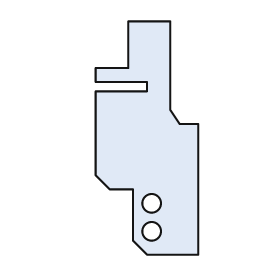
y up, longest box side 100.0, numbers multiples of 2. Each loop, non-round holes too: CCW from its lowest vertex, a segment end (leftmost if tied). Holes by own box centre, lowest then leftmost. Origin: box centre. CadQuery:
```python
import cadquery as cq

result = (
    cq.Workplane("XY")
    .moveTo(0.0, -50.0)
    .lineTo(22.0, -50.0)
    .lineTo(22.0, 6.0)
    .lineTo(14.0, 6.0)
    .lineTo(10.0, 12.0)
    .lineTo(10.0, 50.0)
    .lineTo(-8.0, 50.0)
    .lineTo(-8.0, 30.0)
    .lineTo(-22.0, 30.0)
    .lineTo(-22.0, 24.0)
    .lineTo(0.0, 24.0)
    .lineTo(0.0, 20.0)
    .lineTo(-22.0, 20.0)
    .lineTo(-22.0, -16.0)
    .lineTo(-16.0, -22.0)
    .lineTo(-6.0, -22.0)
    .lineTo(-6.0, -44.0)
    .close()
    .moveTo(2.0, -40.0)
    .circle(4.0)
    .moveTo(2.0, -28.0)
    .circle(4.0)
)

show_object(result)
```